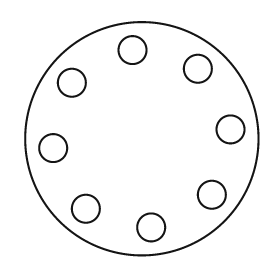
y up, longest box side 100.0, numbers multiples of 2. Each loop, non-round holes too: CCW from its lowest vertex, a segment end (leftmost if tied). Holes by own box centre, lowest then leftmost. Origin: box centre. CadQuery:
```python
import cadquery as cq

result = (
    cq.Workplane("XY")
    .moveTo(0.0, 0.0)
    .circle(50.0)
    .moveTo(4.0, -38.0)
    .circle(6.0)
    .moveTo(-24.0, -30.0)
    .circle(6.0)
    .moveTo(30.0, -24.0)
    .circle(6.0)
    .moveTo(-38.0, -4.0)
    .circle(6.0)
    .moveTo(38.0, 4.0)
    .circle(6.0)
    .moveTo(-30.0, 24.0)
    .circle(6.0)
    .moveTo(24.0, 30.0)
    .circle(6.0)
    .moveTo(-4.0, 38.0)
    .circle(6.0)
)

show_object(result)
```